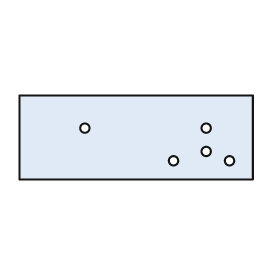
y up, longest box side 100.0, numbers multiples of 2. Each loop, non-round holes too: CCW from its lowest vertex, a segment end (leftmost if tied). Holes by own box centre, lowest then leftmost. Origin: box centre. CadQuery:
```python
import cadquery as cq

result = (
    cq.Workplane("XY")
    .moveTo(-50.0, -18.0)
    .lineTo(50.0, -18.0)
    .lineTo(50.0, 18.0)
    .lineTo(-50.0, 18.0)
    .close()
    .moveTo(16.0, -10.0)
    .circle(2.0)
    .moveTo(40.0, -10.0)
    .circle(2.0)
    .moveTo(30.0, -6.0)
    .circle(2.0)
    .moveTo(-22.0, 4.0)
    .circle(2.0)
    .moveTo(30.0, 4.0)
    .circle(2.0)
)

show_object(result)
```